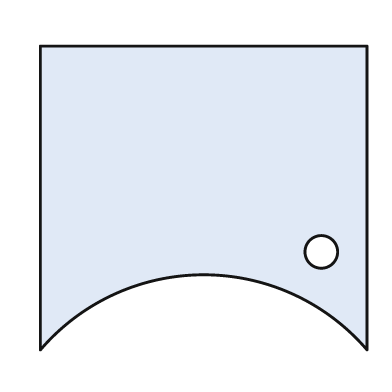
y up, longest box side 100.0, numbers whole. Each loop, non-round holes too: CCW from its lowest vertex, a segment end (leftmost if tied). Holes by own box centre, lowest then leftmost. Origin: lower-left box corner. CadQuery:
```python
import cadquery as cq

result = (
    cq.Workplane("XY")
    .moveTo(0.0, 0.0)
    .threePointArc((50.0, 23.0), (100.0, 0.0))
    .lineTo(100.0, 93.0)
    .lineTo(0.0, 93.0)
    .close()
    .moveTo(86.0, 30.0)
    .circle(5.0)
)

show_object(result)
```